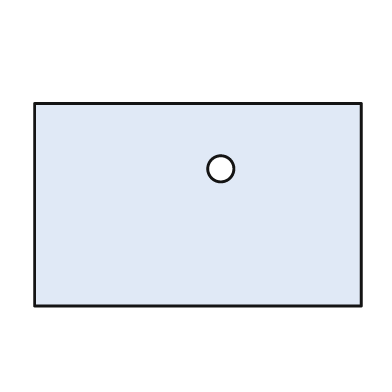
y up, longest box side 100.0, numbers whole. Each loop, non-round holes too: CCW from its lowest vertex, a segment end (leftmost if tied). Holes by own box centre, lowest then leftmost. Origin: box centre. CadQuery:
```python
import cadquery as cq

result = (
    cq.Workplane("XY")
    .moveTo(-50.0, -31.0)
    .lineTo(50.0, -31.0)
    .lineTo(50.0, 31.0)
    .lineTo(-50.0, 31.0)
    .close()
    .moveTo(7.0, 11.0)
    .circle(4.0)
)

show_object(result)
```